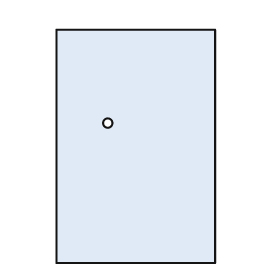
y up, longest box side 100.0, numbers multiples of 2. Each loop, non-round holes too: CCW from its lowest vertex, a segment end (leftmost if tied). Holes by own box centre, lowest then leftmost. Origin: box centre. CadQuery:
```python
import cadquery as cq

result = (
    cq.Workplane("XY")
    .moveTo(-34.0, -50.0)
    .lineTo(34.0, -50.0)
    .lineTo(34.0, 50.0)
    .lineTo(-34.0, 50.0)
    .close()
    .moveTo(-12.0, 10.0)
    .circle(2.0)
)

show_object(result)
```